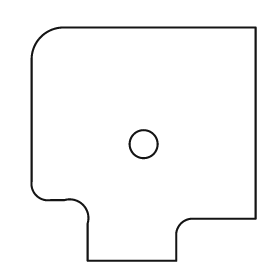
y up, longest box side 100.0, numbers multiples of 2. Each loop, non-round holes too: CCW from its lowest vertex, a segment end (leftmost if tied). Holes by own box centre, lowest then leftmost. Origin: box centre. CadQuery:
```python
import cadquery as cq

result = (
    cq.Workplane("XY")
    .moveTo(-24.0, -50.0)
    .lineTo(14.0, -50.0)
    .lineTo(14.0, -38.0)
    .threePointArc((16.0, -34.0), (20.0, -32.0))
    .lineTo(48.0, -32.0)
    .lineTo(48.0, 50.0)
    .lineTo(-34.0, 50.0)
    .threePointArc((-44.0, 46.0), (-48.0, 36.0))
    .lineTo(-48.0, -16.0)
    .threePointArc((-46.0, -22.0), (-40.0, -24.0))
    .lineTo(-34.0, -24.0)
    .threePointArc((-26.0, -26.0), (-24.0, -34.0))
    .close()
    .moveTo(0.0, 0.0)
    .circle(6.0)
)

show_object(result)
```